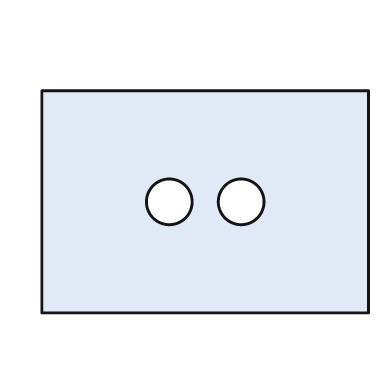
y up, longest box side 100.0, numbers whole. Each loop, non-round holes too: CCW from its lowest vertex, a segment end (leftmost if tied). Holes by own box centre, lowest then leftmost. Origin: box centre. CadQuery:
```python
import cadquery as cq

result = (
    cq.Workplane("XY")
    .moveTo(-50.0, -34.0)
    .lineTo(50.0, -34.0)
    .lineTo(50.0, 34.0)
    .lineTo(-50.0, 34.0)
    .close()
    .moveTo(-11.0, 0.0)
    .circle(7.0)
    .moveTo(11.0, 0.0)
    .circle(7.0)
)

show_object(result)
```